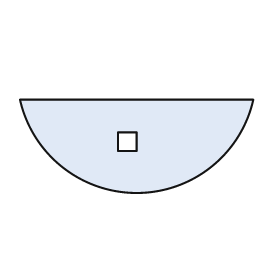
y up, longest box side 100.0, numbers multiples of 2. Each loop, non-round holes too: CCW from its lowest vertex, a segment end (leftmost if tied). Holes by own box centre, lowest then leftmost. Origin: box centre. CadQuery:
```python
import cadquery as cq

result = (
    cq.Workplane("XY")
    .moveTo(-50.0, 20.0)
    .threePointArc((0.0, -20.0), (50.0, 20.0))
    .close()
    .moveTo(-8.0, -2.0)
    .lineTo(0.0, -2.0)
    .lineTo(0.0, 6.0)
    .lineTo(-8.0, 6.0)
    .close()
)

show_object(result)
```